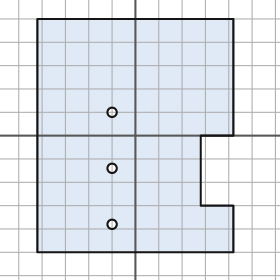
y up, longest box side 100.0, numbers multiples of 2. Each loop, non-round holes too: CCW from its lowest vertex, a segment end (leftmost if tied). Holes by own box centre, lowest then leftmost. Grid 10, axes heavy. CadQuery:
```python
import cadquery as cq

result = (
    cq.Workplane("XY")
    .moveTo(-42.0, -50.0)
    .lineTo(42.0, -50.0)
    .lineTo(42.0, -30.0)
    .lineTo(28.0, -30.0)
    .lineTo(28.0, 0.0)
    .lineTo(42.0, 0.0)
    .lineTo(42.0, 50.0)
    .lineTo(-42.0, 50.0)
    .close()
    .moveTo(-10.0, -38.0)
    .circle(2.0)
    .moveTo(-10.0, -14.0)
    .circle(2.0)
    .moveTo(-10.0, 10.0)
    .circle(2.0)
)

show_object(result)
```